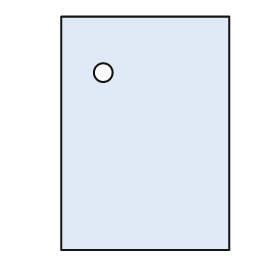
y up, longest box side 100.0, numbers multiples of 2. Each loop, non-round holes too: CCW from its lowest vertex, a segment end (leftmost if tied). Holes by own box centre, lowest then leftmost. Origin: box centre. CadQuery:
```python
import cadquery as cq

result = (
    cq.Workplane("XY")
    .moveTo(-36.0, -50.0)
    .lineTo(36.0, -50.0)
    .lineTo(36.0, 50.0)
    .lineTo(-36.0, 50.0)
    .close()
    .moveTo(-18.0, 26.0)
    .circle(4.0)
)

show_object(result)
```